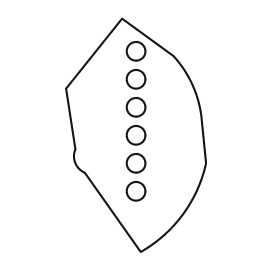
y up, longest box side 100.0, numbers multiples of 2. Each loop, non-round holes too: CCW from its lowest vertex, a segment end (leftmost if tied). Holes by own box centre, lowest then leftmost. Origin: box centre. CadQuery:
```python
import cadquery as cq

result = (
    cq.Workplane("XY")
    .moveTo(2.0, -50.0)
    .threePointArc((20.0, -34.0), (30.0, -12.0))
    .lineTo(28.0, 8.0)
    .threePointArc((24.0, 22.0), (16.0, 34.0))
    .lineTo(-6.0, 50.0)
    .lineTo(-30.0, 20.0)
    .lineTo(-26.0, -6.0)
    .threePointArc((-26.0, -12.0), (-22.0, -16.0))
    .close()
    .moveTo(0.0, -24.0)
    .circle(4.0)
    .moveTo(0.0, -12.0)
    .circle(4.0)
    .moveTo(0.0, 0.0)
    .circle(4.0)
    .moveTo(0.0, 12.0)
    .circle(4.0)
    .moveTo(0.0, 24.0)
    .circle(4.0)
    .moveTo(0.0, 36.0)
    .circle(4.0)
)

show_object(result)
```